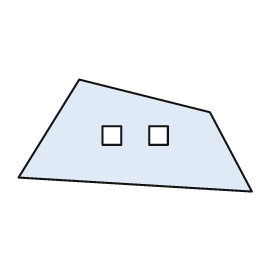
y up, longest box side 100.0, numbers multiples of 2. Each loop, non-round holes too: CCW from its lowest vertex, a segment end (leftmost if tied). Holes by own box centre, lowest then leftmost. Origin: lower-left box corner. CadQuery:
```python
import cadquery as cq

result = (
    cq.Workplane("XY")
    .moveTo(100.0, 0.0)
    .lineTo(82.0, 34.0)
    .lineTo(26.0, 48.0)
    .lineTo(0.0, 6.0)
    .close()
    .moveTo(36.0, 20.0)
    .lineTo(44.0, 20.0)
    .lineTo(44.0, 28.0)
    .lineTo(36.0, 28.0)
    .close()
    .moveTo(56.0, 20.0)
    .lineTo(64.0, 20.0)
    .lineTo(64.0, 28.0)
    .lineTo(56.0, 28.0)
    .close()
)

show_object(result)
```